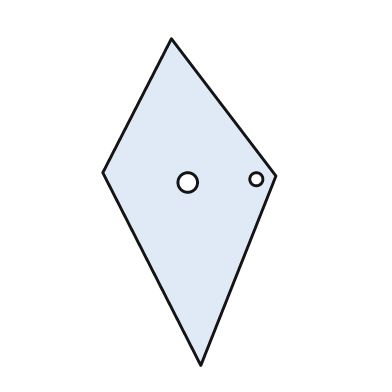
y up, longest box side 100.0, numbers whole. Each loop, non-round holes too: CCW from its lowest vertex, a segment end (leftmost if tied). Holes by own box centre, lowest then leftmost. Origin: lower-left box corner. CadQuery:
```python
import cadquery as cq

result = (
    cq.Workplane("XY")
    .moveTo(30.0, 0.0)
    .lineTo(53.0, 58.0)
    .lineTo(21.0, 100.0)
    .lineTo(0.0, 59.0)
    .close()
    .moveTo(26.0, 56.0)
    .circle(3.0)
    .moveTo(47.0, 57.0)
    .circle(2.0)
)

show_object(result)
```